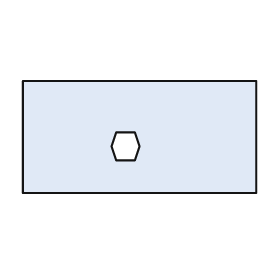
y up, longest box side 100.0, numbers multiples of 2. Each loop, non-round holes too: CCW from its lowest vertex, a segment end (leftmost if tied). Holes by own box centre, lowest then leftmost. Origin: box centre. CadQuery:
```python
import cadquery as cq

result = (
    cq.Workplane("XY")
    .moveTo(-50.0, -24.0)
    .lineTo(50.0, -24.0)
    .lineTo(50.0, 24.0)
    .lineTo(-50.0, 24.0)
    .close()
    .moveTo(-10.0, -10.0)
    .lineTo(-2.0, -10.0)
    .lineTo(0.0, -4.0)
    .lineTo(-2.0, 2.0)
    .lineTo(-10.0, 2.0)
    .lineTo(-12.0, -4.0)
    .close()
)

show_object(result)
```